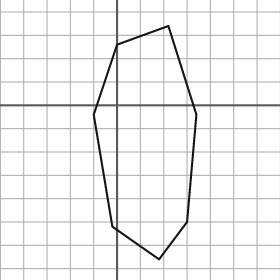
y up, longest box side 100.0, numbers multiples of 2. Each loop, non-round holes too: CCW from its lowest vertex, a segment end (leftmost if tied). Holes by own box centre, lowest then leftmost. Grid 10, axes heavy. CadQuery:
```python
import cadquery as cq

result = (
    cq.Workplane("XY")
    .moveTo(18.0, -66.0)
    .lineTo(30.0, -50.0)
    .lineTo(34.0, -4.0)
    .lineTo(22.0, 34.0)
    .lineTo(0.0, 26.0)
    .lineTo(-10.0, -4.0)
    .lineTo(-2.0, -52.0)
    .close()
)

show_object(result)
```